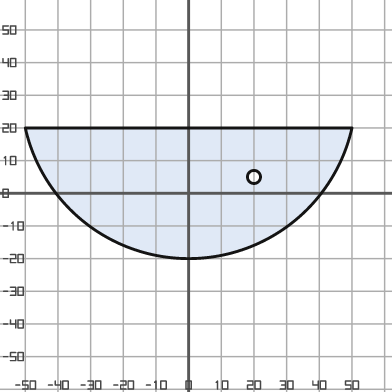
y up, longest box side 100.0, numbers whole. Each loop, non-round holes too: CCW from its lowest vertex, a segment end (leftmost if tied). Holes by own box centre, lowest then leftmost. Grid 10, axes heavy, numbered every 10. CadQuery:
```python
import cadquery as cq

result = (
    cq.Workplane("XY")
    .moveTo(-50.0, 20.0)
    .threePointArc((0.0, -20.0), (50.0, 20.0))
    .close()
    .moveTo(20.0, 5.0)
    .circle(2.0)
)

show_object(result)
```